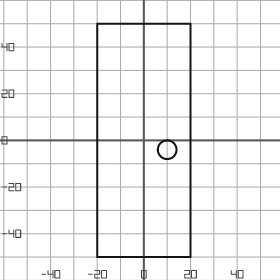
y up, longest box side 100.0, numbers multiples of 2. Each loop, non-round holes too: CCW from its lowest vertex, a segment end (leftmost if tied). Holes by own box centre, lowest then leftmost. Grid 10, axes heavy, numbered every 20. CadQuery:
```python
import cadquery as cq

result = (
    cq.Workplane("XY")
    .moveTo(-20.0, -50.0)
    .lineTo(20.0, -50.0)
    .lineTo(20.0, 50.0)
    .lineTo(-20.0, 50.0)
    .close()
    .moveTo(10.0, -4.0)
    .circle(4.0)
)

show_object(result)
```